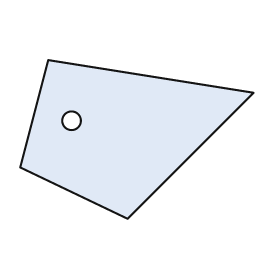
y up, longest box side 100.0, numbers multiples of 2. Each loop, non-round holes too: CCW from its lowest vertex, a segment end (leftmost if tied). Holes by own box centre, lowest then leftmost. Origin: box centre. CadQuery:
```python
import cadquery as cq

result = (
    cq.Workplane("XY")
    .moveTo(-4.0, -34.0)
    .lineTo(50.0, 20.0)
    .lineTo(-38.0, 34.0)
    .lineTo(-50.0, -12.0)
    .close()
    .moveTo(-28.0, 8.0)
    .circle(4.0)
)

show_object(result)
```